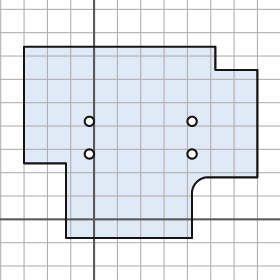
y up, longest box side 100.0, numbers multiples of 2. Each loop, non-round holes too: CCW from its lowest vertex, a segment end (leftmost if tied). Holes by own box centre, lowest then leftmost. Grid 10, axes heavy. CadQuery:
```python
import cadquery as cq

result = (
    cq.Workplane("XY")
    .moveTo(-12.0, -8.0)
    .lineTo(42.0, -8.0)
    .lineTo(42.0, 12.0)
    .threePointArc((44.0, 16.0), (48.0, 18.0))
    .lineTo(70.0, 18.0)
    .lineTo(70.0, 64.0)
    .lineTo(52.0, 64.0)
    .lineTo(52.0, 74.0)
    .lineTo(-30.0, 74.0)
    .lineTo(-30.0, 24.0)
    .lineTo(-12.0, 24.0)
    .close()
    .moveTo(-2.0, 28.0)
    .circle(2.0)
    .moveTo(42.0, 28.0)
    .circle(2.0)
    .moveTo(-2.0, 42.0)
    .circle(2.0)
    .moveTo(42.0, 42.0)
    .circle(2.0)
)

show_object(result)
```